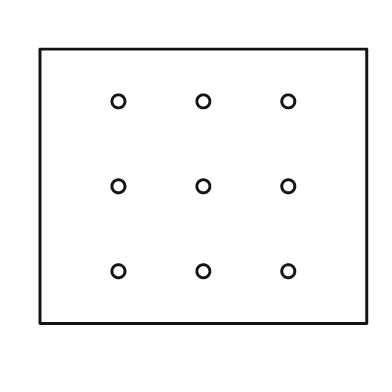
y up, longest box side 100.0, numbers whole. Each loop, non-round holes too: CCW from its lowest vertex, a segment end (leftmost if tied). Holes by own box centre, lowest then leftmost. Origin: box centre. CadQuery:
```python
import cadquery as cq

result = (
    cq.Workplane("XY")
    .moveTo(-50.0, -42.0)
    .lineTo(50.0, -42.0)
    .lineTo(50.0, 42.0)
    .lineTo(-50.0, 42.0)
    .close()
    .moveTo(-26.0, -26.0)
    .circle(2.0)
    .moveTo(0.0, -26.0)
    .circle(2.0)
    .moveTo(26.0, -26.0)
    .circle(2.0)
    .moveTo(-26.0, 0.0)
    .circle(2.0)
    .moveTo(0.0, 0.0)
    .circle(2.0)
    .moveTo(26.0, 0.0)
    .circle(2.0)
    .moveTo(-26.0, 26.0)
    .circle(2.0)
    .moveTo(0.0, 26.0)
    .circle(2.0)
    .moveTo(26.0, 26.0)
    .circle(2.0)
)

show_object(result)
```